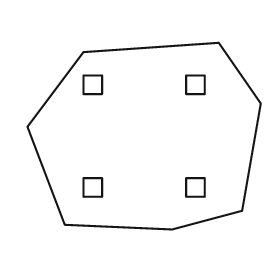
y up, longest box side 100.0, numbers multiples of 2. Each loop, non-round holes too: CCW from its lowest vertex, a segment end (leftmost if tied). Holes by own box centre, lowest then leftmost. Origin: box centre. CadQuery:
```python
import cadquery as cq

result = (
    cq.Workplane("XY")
    .moveTo(12.0, -40.0)
    .lineTo(42.0, -32.0)
    .lineTo(50.0, 14.0)
    .lineTo(32.0, 40.0)
    .lineTo(-26.0, 36.0)
    .lineTo(-50.0, 4.0)
    .lineTo(-34.0, -38.0)
    .close()
    .moveTo(-26.0, -26.0)
    .lineTo(-18.0, -26.0)
    .lineTo(-18.0, -18.0)
    .lineTo(-26.0, -18.0)
    .close()
    .moveTo(18.0, -26.0)
    .lineTo(26.0, -26.0)
    .lineTo(26.0, -18.0)
    .lineTo(18.0, -18.0)
    .close()
    .moveTo(-26.0, 18.0)
    .lineTo(-18.0, 18.0)
    .lineTo(-18.0, 26.0)
    .lineTo(-26.0, 26.0)
    .close()
    .moveTo(18.0, 18.0)
    .lineTo(26.0, 18.0)
    .lineTo(26.0, 26.0)
    .lineTo(18.0, 26.0)
    .close()
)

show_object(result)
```